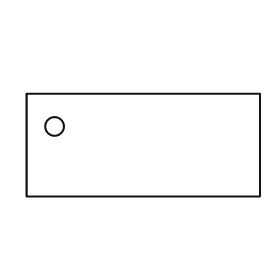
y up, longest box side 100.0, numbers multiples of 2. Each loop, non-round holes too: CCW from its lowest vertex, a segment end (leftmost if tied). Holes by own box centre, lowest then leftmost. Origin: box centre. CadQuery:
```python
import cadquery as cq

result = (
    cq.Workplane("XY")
    .moveTo(-50.0, -22.0)
    .lineTo(50.0, -22.0)
    .lineTo(50.0, 22.0)
    .lineTo(-50.0, 22.0)
    .close()
    .moveTo(-38.0, 8.0)
    .circle(4.0)
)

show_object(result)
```